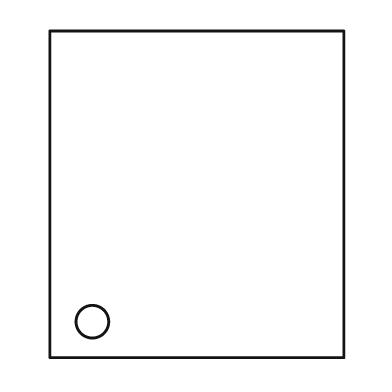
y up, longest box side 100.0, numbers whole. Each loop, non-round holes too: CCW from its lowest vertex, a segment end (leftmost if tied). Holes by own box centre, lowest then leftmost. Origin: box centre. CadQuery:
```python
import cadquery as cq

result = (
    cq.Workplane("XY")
    .moveTo(-45.0, -50.0)
    .lineTo(45.0, -50.0)
    .lineTo(45.0, 50.0)
    .lineTo(-45.0, 50.0)
    .close()
    .moveTo(-32.0, -39.0)
    .circle(5.0)
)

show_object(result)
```